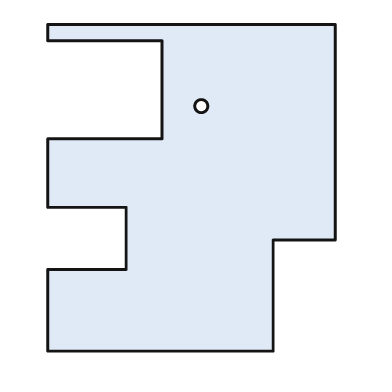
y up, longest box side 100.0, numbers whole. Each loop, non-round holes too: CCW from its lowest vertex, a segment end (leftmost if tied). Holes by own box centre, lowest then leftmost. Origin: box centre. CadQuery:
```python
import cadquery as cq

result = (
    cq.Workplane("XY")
    .moveTo(-44.0, -50.0)
    .lineTo(25.0, -50.0)
    .lineTo(25.0, -16.0)
    .lineTo(44.0, -16.0)
    .lineTo(44.0, 50.0)
    .lineTo(-44.0, 50.0)
    .lineTo(-44.0, 45.0)
    .lineTo(-9.0, 45.0)
    .lineTo(-9.0, 15.0)
    .lineTo(-44.0, 15.0)
    .lineTo(-44.0, -6.0)
    .lineTo(-20.0, -6.0)
    .lineTo(-20.0, -25.0)
    .lineTo(-44.0, -25.0)
    .close()
    .moveTo(3.0, 25.0)
    .circle(2.0)
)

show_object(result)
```